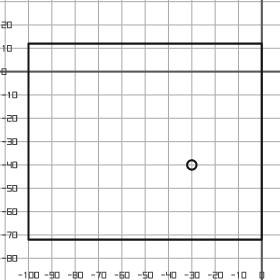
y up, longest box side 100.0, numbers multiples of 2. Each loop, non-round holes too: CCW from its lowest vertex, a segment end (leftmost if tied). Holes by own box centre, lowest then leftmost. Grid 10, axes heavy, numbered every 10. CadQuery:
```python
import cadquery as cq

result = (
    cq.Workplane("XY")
    .moveTo(-100.0, -72.0)
    .lineTo(0.0, -72.0)
    .lineTo(0.0, 12.0)
    .lineTo(-100.0, 12.0)
    .close()
    .moveTo(-30.0, -40.0)
    .circle(2.0)
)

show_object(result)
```